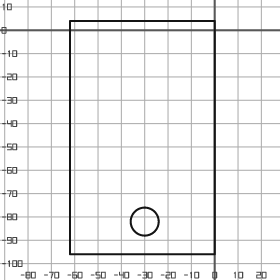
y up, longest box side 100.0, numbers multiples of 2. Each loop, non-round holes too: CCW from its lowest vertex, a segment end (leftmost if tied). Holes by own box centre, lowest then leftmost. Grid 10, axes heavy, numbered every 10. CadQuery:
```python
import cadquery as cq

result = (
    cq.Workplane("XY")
    .moveTo(-62.0, -96.0)
    .lineTo(0.0, -96.0)
    .lineTo(0.0, 4.0)
    .lineTo(-62.0, 4.0)
    .close()
    .moveTo(-30.0, -82.0)
    .circle(6.0)
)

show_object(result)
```